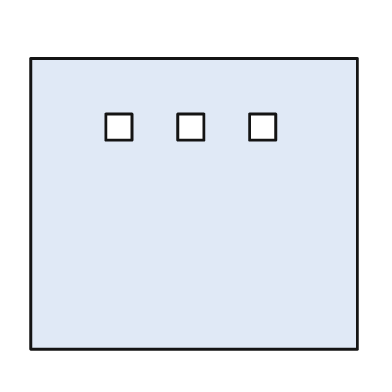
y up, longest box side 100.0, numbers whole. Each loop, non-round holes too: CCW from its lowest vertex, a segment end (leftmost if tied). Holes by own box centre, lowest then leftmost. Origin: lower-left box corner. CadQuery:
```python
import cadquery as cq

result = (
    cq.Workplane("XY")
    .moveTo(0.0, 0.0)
    .lineTo(100.0, 0.0)
    .lineTo(100.0, 89.0)
    .lineTo(0.0, 89.0)
    .close()
    .moveTo(23.0, 64.0)
    .lineTo(31.0, 64.0)
    .lineTo(31.0, 72.0)
    .lineTo(23.0, 72.0)
    .close()
    .moveTo(45.0, 64.0)
    .lineTo(53.0, 64.0)
    .lineTo(53.0, 72.0)
    .lineTo(45.0, 72.0)
    .close()
    .moveTo(67.0, 64.0)
    .lineTo(75.0, 64.0)
    .lineTo(75.0, 72.0)
    .lineTo(67.0, 72.0)
    .close()
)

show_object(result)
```